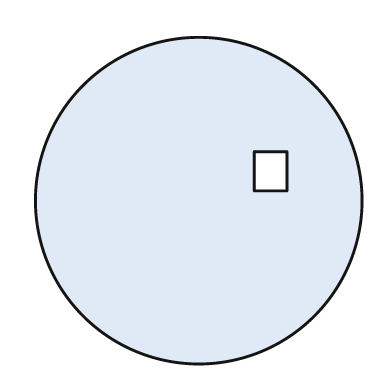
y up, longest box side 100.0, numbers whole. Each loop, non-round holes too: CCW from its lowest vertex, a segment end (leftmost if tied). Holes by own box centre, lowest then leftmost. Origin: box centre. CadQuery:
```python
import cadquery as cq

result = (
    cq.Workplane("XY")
    .moveTo(0.0, 0.0)
    .circle(50.0)
    .moveTo(17.0, 3.0)
    .lineTo(27.0, 3.0)
    .lineTo(27.0, 15.0)
    .lineTo(17.0, 15.0)
    .close()
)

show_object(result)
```